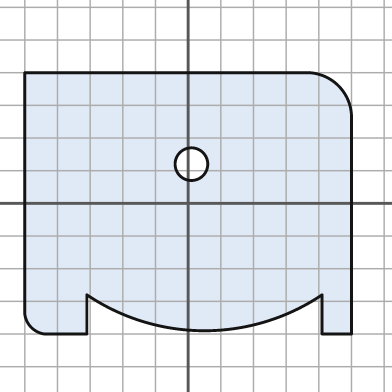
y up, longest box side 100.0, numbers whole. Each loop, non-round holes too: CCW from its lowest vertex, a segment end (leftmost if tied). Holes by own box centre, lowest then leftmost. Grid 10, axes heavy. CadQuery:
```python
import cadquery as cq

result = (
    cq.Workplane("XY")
    .moveTo(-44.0, -40.0)
    .lineTo(-31.0, -40.0)
    .lineTo(-31.0, -28.0)
    .threePointArc((5.0, -39.0), (41.0, -28.0))
    .lineTo(41.0, -40.0)
    .lineTo(50.0, -40.0)
    .lineTo(50.0, 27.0)
    .threePointArc((46.0, 36.0), (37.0, 40.0))
    .lineTo(-50.0, 40.0)
    .lineTo(-50.0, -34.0)
    .threePointArc((-48.0, -38.0), (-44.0, -40.0))
    .close()
    .moveTo(1.0, 12.0)
    .circle(5.0)
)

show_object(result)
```